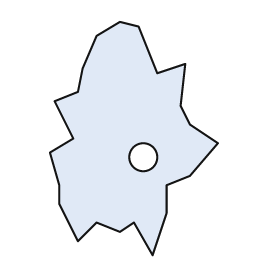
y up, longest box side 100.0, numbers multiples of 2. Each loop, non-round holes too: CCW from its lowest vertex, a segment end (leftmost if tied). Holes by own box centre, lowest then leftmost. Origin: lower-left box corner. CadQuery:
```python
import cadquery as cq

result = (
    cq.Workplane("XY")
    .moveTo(44.0, 0.0)
    .lineTo(50.0, 18.0)
    .lineTo(50.0, 30.0)
    .lineTo(60.0, 34.0)
    .lineTo(72.0, 48.0)
    .lineTo(60.0, 56.0)
    .lineTo(56.0, 64.0)
    .lineTo(58.0, 82.0)
    .lineTo(46.0, 78.0)
    .lineTo(38.0, 98.0)
    .lineTo(30.0, 100.0)
    .lineTo(20.0, 94.0)
    .lineTo(14.0, 80.0)
    .lineTo(12.0, 70.0)
    .lineTo(2.0, 66.0)
    .lineTo(10.0, 50.0)
    .lineTo(0.0, 44.0)
    .lineTo(4.0, 30.0)
    .lineTo(4.0, 22.0)
    .lineTo(12.0, 6.0)
    .lineTo(20.0, 14.0)
    .lineTo(30.0, 10.0)
    .lineTo(36.0, 14.0)
    .close()
    .moveTo(40.0, 42.0)
    .circle(6.0)
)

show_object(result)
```